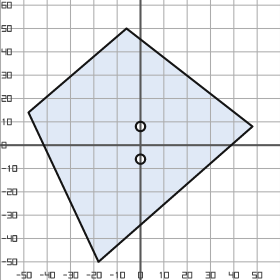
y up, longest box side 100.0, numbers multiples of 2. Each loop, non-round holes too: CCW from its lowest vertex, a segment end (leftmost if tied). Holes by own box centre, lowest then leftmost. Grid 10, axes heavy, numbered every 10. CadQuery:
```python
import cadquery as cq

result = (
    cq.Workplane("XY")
    .moveTo(-18.0, -50.0)
    .lineTo(48.0, 8.0)
    .lineTo(-6.0, 50.0)
    .lineTo(-48.0, 14.0)
    .close()
    .moveTo(0.0, -6.0)
    .circle(2.0)
    .moveTo(0.0, 8.0)
    .circle(2.0)
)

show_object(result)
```